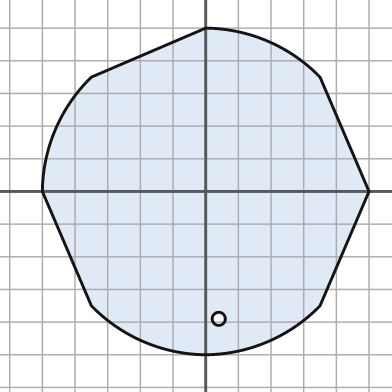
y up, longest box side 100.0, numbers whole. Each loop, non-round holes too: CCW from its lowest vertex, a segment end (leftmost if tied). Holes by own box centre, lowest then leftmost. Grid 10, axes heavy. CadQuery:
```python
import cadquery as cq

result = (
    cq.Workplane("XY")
    .moveTo(0.0, -50.0)
    .threePointArc((19.0, -46.0), (35.0, -35.0))
    .lineTo(50.0, 0.0)
    .lineTo(35.0, 35.0)
    .threePointArc((19.0, 46.0), (0.0, 50.0))
    .lineTo(-35.0, 35.0)
    .threePointArc((-46.0, 19.0), (-50.0, 0.0))
    .lineTo(-35.0, -35.0)
    .threePointArc((-19.0, -46.0), (0.0, -50.0))
    .close()
    .moveTo(4.0, -39.0)
    .circle(2.0)
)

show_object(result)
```